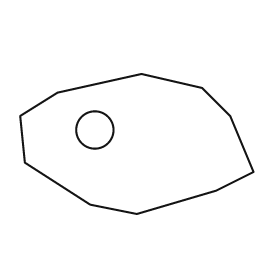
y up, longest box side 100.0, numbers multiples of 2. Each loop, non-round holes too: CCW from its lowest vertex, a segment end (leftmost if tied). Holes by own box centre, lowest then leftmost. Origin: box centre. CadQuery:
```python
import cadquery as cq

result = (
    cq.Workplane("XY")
    .moveTo(0.0, -30.0)
    .lineTo(34.0, -20.0)
    .lineTo(50.0, -12.0)
    .lineTo(40.0, 12.0)
    .lineTo(28.0, 24.0)
    .lineTo(2.0, 30.0)
    .lineTo(-34.0, 22.0)
    .lineTo(-50.0, 12.0)
    .lineTo(-48.0, -8.0)
    .lineTo(-20.0, -26.0)
    .close()
    .moveTo(-18.0, 6.0)
    .circle(8.0)
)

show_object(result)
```